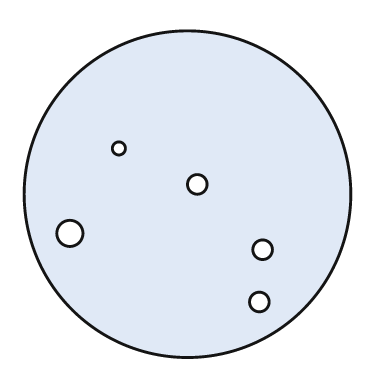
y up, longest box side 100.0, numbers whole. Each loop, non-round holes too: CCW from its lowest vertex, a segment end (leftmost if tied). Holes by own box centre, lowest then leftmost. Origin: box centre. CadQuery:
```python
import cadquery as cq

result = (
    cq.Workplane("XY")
    .moveTo(0.0, 0.0)
    .circle(50.0)
    .moveTo(22.0, -33.0)
    .circle(3.0)
    .moveTo(23.0, -17.0)
    .circle(3.0)
    .moveTo(-36.0, -12.0)
    .circle(4.0)
    .moveTo(3.0, 3.0)
    .circle(3.0)
    .moveTo(-21.0, 14.0)
    .circle(2.0)
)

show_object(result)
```